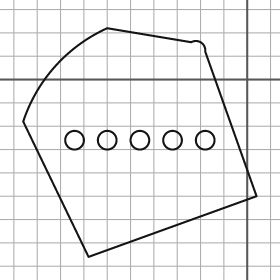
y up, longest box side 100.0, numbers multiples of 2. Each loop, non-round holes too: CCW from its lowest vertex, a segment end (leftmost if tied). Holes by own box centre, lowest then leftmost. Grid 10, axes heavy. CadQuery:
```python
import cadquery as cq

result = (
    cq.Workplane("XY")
    .moveTo(-68.0, -76.0)
    .lineTo(4.0, -50.0)
    .lineTo(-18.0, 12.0)
    .threePointArc((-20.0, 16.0), (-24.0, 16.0))
    .lineTo(-60.0, 22.0)
    .threePointArc((-82.0, 6.0), (-96.0, -18.0))
    .close()
    .moveTo(-74.0, -26.0)
    .circle(4.0)
    .moveTo(-60.0, -26.0)
    .circle(4.0)
    .moveTo(-46.0, -26.0)
    .circle(4.0)
    .moveTo(-32.0, -26.0)
    .circle(4.0)
    .moveTo(-18.0, -26.0)
    .circle(4.0)
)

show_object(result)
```